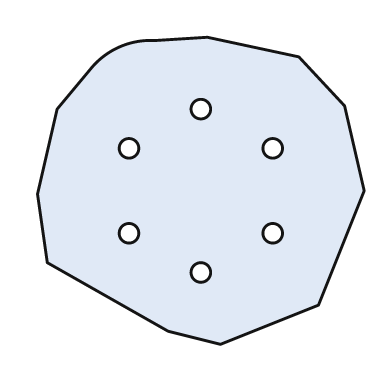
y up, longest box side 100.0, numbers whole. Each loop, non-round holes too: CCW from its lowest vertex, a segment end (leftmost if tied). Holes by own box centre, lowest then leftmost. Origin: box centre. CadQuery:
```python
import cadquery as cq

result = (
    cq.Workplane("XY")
    .moveTo(6.0, -47.0)
    .lineTo(36.0, -35.0)
    .lineTo(50.0, 0.0)
    .lineTo(44.0, 26.0)
    .lineTo(30.0, 41.0)
    .lineTo(2.0, 47.0)
    .lineTo(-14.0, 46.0)
    .threePointArc((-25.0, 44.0), (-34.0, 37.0))
    .lineTo(-44.0, 25.0)
    .lineTo(-50.0, -1.0)
    .lineTo(-47.0, -22.0)
    .lineTo(-10.0, -43.0)
    .close()
    .moveTo(0.0, -25.0)
    .circle(3.0)
    .moveTo(-22.0, -13.0)
    .circle(3.0)
    .moveTo(22.0, -13.0)
    .circle(3.0)
    .moveTo(-22.0, 13.0)
    .circle(3.0)
    .moveTo(22.0, 13.0)
    .circle(3.0)
    .moveTo(0.0, 25.0)
    .circle(3.0)
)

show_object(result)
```